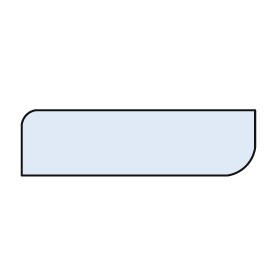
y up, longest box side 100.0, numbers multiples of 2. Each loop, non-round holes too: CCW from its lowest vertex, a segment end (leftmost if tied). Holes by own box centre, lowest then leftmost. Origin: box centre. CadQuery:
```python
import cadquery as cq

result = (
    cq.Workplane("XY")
    .moveTo(-50.0, -14.0)
    .lineTo(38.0, -14.0)
    .threePointArc((46.0, -10.0), (50.0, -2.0))
    .lineTo(50.0, 14.0)
    .lineTo(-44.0, 14.0)
    .threePointArc((-48.0, 12.0), (-50.0, 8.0))
    .close()
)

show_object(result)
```